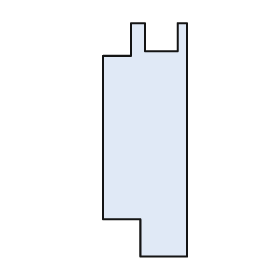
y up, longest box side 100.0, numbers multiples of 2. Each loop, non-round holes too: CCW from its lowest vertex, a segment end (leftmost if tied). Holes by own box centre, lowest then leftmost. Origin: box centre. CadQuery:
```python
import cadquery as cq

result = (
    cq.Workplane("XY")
    .moveTo(-2.0, -50.0)
    .lineTo(18.0, -50.0)
    .lineTo(18.0, 50.0)
    .lineTo(14.0, 50.0)
    .lineTo(14.0, 38.0)
    .lineTo(0.0, 38.0)
    .lineTo(0.0, 50.0)
    .lineTo(-6.0, 50.0)
    .lineTo(-6.0, 36.0)
    .lineTo(-18.0, 36.0)
    .lineTo(-18.0, -34.0)
    .lineTo(-2.0, -34.0)
    .close()
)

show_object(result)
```